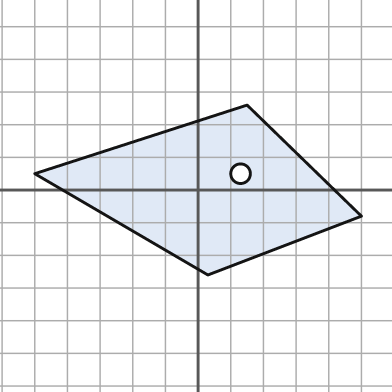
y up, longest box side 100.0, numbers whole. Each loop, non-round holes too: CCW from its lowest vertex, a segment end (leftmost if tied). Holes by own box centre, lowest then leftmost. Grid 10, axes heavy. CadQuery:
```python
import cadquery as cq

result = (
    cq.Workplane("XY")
    .moveTo(3.0, -26.0)
    .lineTo(50.0, -8.0)
    .lineTo(15.0, 26.0)
    .lineTo(-50.0, 5.0)
    .close()
    .moveTo(13.0, 5.0)
    .circle(3.0)
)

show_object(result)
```